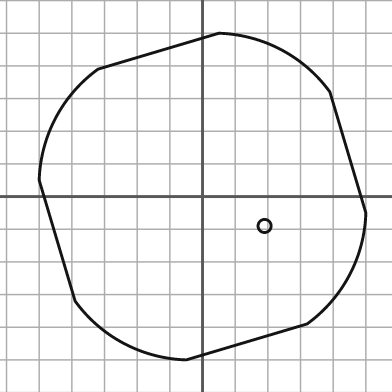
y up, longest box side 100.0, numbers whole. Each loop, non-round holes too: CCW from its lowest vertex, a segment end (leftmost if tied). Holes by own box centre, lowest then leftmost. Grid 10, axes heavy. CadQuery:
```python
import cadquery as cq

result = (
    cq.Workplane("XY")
    .moveTo(-5.0, -50.0)
    .lineTo(32.0, -39.0)
    .threePointArc((45.0, -24.0), (50.0, -5.0))
    .lineTo(39.0, 32.0)
    .threePointArc((24.0, 45.0), (5.0, 50.0))
    .lineTo(-32.0, 39.0)
    .threePointArc((-45.0, 24.0), (-50.0, 5.0))
    .lineTo(-39.0, -32.0)
    .threePointArc((-24.0, -45.0), (-5.0, -50.0))
    .close()
    .moveTo(19.0, -9.0)
    .circle(2.0)
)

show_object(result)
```